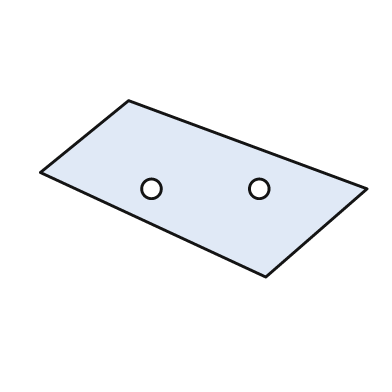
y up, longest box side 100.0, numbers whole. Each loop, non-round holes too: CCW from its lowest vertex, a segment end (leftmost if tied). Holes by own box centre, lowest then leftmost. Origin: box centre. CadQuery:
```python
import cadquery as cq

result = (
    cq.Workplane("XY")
    .moveTo(19.0, -27.0)
    .lineTo(50.0, 0.0)
    .lineTo(-23.0, 27.0)
    .lineTo(-50.0, 5.0)
    .close()
    .moveTo(-16.0, 0.0)
    .circle(3.0)
    .moveTo(17.0, 0.0)
    .circle(3.0)
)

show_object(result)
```